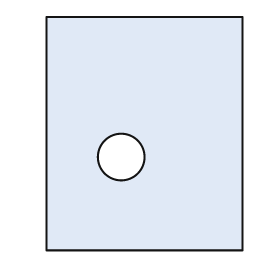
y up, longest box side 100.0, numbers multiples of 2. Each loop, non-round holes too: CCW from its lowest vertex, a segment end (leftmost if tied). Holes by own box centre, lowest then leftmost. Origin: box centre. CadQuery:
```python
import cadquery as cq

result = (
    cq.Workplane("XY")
    .moveTo(-42.0, -50.0)
    .lineTo(42.0, -50.0)
    .lineTo(42.0, 50.0)
    .lineTo(-42.0, 50.0)
    .close()
    .moveTo(-10.0, -10.0)
    .circle(10.0)
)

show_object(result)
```